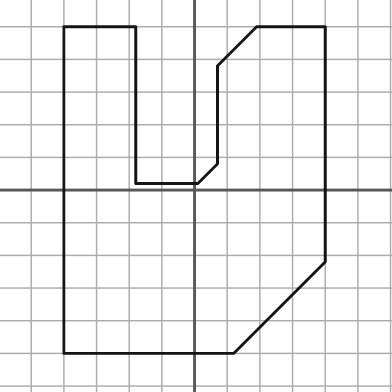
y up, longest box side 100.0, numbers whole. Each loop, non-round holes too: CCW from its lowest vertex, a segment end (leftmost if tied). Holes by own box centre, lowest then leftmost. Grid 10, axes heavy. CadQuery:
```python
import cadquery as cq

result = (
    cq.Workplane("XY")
    .moveTo(-40.0, -50.0)
    .lineTo(12.0, -50.0)
    .lineTo(40.0, -22.0)
    .lineTo(40.0, 50.0)
    .lineTo(19.0, 50.0)
    .lineTo(7.0, 38.0)
    .lineTo(7.0, 8.0)
    .lineTo(1.0, 2.0)
    .lineTo(-18.0, 2.0)
    .lineTo(-18.0, 50.0)
    .lineTo(-40.0, 50.0)
    .close()
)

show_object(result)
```